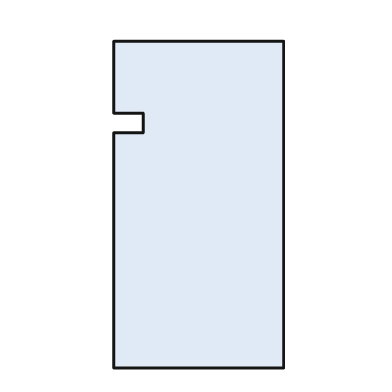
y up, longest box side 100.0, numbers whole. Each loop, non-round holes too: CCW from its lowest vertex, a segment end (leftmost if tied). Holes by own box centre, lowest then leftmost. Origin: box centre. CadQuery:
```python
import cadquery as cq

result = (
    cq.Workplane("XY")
    .moveTo(-26.0, -50.0)
    .lineTo(26.0, -50.0)
    .lineTo(26.0, 50.0)
    .lineTo(-26.0, 50.0)
    .lineTo(-26.0, 28.0)
    .lineTo(-17.0, 28.0)
    .lineTo(-17.0, 22.0)
    .lineTo(-26.0, 22.0)
    .close()
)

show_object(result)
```